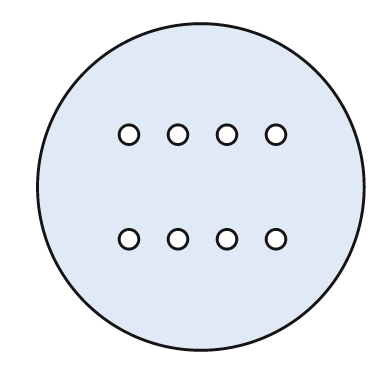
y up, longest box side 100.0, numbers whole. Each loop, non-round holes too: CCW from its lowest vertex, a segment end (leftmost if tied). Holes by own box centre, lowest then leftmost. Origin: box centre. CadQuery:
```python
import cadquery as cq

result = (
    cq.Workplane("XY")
    .moveTo(0.0, 0.0)
    .circle(50.0)
    .moveTo(-22.0, -16.0)
    .circle(3.0)
    .moveTo(-7.0, -16.0)
    .circle(3.0)
    .moveTo(8.0, -16.0)
    .circle(3.0)
    .moveTo(23.0, -16.0)
    .circle(3.0)
    .moveTo(-22.0, 16.0)
    .circle(3.0)
    .moveTo(-7.0, 16.0)
    .circle(3.0)
    .moveTo(8.0, 16.0)
    .circle(3.0)
    .moveTo(23.0, 16.0)
    .circle(3.0)
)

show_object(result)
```